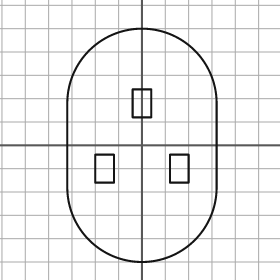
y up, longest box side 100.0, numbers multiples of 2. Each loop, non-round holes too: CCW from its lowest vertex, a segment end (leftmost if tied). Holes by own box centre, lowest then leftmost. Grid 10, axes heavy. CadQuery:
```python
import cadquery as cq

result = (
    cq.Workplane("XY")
    .moveTo(-32.0, -18.0)
    .threePointArc((0.0, -50.0), (32.0, -18.0))
    .lineTo(32.0, 18.0)
    .threePointArc((0.0, 50.0), (-32.0, 18.0))
    .close()
    .moveTo(-20.0, -16.0)
    .lineTo(-12.0, -16.0)
    .lineTo(-12.0, -4.0)
    .lineTo(-20.0, -4.0)
    .close()
    .moveTo(12.0, -16.0)
    .lineTo(20.0, -16.0)
    .lineTo(20.0, -4.0)
    .lineTo(12.0, -4.0)
    .close()
    .moveTo(-4.0, 12.0)
    .lineTo(4.0, 12.0)
    .lineTo(4.0, 24.0)
    .lineTo(-4.0, 24.0)
    .close()
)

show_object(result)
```